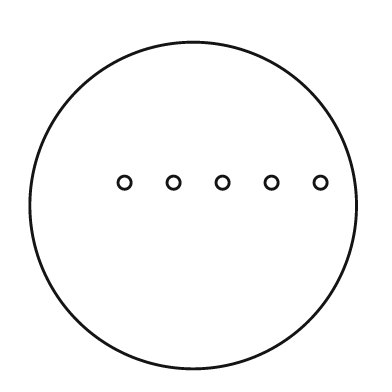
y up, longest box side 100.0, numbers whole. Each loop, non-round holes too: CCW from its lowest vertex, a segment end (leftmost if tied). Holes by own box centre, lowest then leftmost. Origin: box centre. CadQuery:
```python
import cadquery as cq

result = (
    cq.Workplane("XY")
    .moveTo(0.0, 0.0)
    .circle(50.0)
    .moveTo(-21.0, 7.0)
    .circle(2.0)
    .moveTo(-6.0, 7.0)
    .circle(2.0)
    .moveTo(9.0, 7.0)
    .circle(2.0)
    .moveTo(24.0, 7.0)
    .circle(2.0)
    .moveTo(39.0, 7.0)
    .circle(2.0)
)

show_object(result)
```